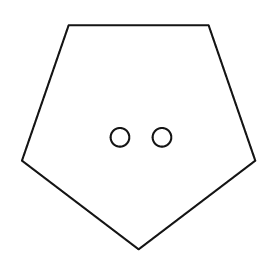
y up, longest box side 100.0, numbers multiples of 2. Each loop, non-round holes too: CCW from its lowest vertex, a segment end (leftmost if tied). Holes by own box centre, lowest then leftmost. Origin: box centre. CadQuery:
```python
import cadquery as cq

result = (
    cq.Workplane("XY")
    .moveTo(0.0, -48.0)
    .lineTo(50.0, -10.0)
    .lineTo(30.0, 48.0)
    .lineTo(-30.0, 48.0)
    .lineTo(-50.0, -10.0)
    .close()
    .moveTo(-8.0, 0.0)
    .circle(4.0)
    .moveTo(10.0, 0.0)
    .circle(4.0)
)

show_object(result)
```